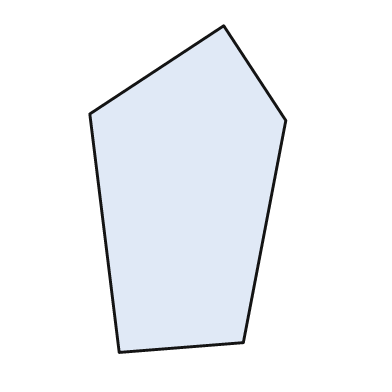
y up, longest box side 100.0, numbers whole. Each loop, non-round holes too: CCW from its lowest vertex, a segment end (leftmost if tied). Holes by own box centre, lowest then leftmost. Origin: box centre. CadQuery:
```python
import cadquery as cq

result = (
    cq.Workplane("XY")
    .moveTo(-21.0, -50.0)
    .lineTo(17.0, -47.0)
    .lineTo(30.0, 21.0)
    .lineTo(11.0, 50.0)
    .lineTo(-30.0, 23.0)
    .close()
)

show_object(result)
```